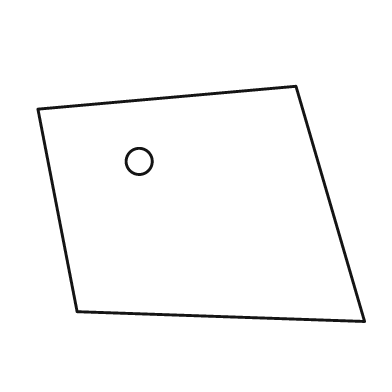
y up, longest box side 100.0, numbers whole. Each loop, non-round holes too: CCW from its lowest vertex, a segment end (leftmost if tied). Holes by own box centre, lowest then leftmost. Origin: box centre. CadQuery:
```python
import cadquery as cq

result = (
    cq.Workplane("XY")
    .moveTo(50.0, -36.0)
    .lineTo(29.0, 36.0)
    .lineTo(-50.0, 29.0)
    .lineTo(-38.0, -33.0)
    .close()
    .moveTo(-19.0, 13.0)
    .circle(4.0)
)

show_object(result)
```